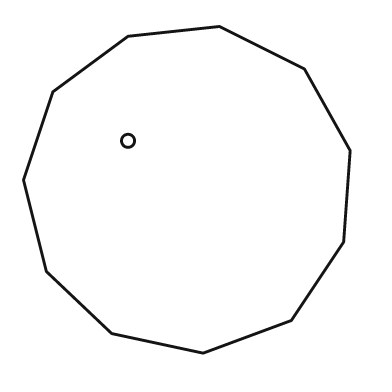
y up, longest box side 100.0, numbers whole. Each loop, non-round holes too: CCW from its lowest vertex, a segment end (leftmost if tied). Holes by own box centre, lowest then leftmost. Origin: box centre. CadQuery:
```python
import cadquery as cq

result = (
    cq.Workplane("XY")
    .moveTo(5.0, -50.0)
    .lineTo(32.0, -40.0)
    .lineTo(48.0, -16.0)
    .lineTo(50.0, 12.0)
    .lineTo(36.0, 37.0)
    .lineTo(10.0, 50.0)
    .lineTo(-18.0, 47.0)
    .lineTo(-41.0, 30.0)
    .lineTo(-50.0, 3.0)
    .lineTo(-43.0, -25.0)
    .lineTo(-23.0, -44.0)
    .close()
    .moveTo(-18.0, 15.0)
    .circle(2.0)
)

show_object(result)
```